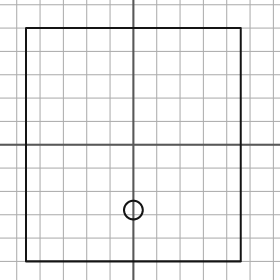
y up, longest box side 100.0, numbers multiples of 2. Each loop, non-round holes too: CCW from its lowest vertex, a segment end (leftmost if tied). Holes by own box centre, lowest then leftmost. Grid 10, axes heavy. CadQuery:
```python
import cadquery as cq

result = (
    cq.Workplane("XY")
    .moveTo(-46.0, -50.0)
    .lineTo(46.0, -50.0)
    .lineTo(46.0, 50.0)
    .lineTo(-46.0, 50.0)
    .close()
    .moveTo(0.0, -28.0)
    .circle(4.0)
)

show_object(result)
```